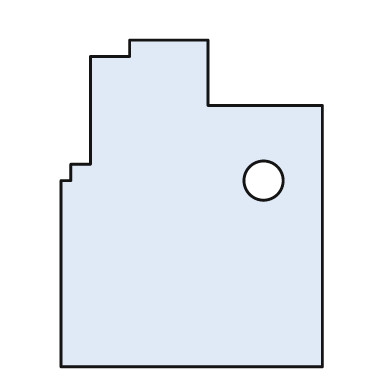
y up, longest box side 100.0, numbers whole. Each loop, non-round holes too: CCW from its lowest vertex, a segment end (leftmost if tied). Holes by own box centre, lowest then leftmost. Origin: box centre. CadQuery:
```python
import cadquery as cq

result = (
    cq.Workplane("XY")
    .moveTo(-40.0, -50.0)
    .lineTo(40.0, -50.0)
    .lineTo(40.0, 30.0)
    .lineTo(5.0, 30.0)
    .lineTo(5.0, 50.0)
    .lineTo(-19.0, 50.0)
    .lineTo(-19.0, 45.0)
    .lineTo(-31.0, 45.0)
    .lineTo(-31.0, 12.0)
    .lineTo(-37.0, 12.0)
    .lineTo(-37.0, 7.0)
    .lineTo(-40.0, 7.0)
    .close()
    .moveTo(22.0, 7.0)
    .circle(6.0)
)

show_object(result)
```